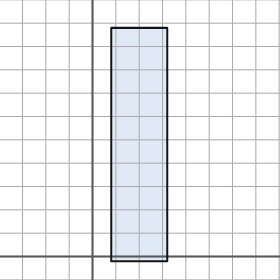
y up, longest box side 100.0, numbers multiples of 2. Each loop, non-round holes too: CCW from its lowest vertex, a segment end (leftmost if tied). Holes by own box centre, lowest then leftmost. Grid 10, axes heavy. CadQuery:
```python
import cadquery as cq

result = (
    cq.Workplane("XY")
    .moveTo(8.0, -2.0)
    .lineTo(32.0, -2.0)
    .lineTo(32.0, 98.0)
    .lineTo(8.0, 98.0)
    .close()
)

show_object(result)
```